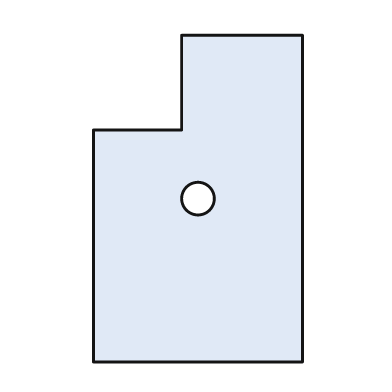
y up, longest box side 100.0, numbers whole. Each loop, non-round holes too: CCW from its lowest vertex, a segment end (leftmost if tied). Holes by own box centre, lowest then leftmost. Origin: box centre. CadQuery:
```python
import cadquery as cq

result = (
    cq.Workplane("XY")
    .moveTo(-32.0, -50.0)
    .lineTo(32.0, -50.0)
    .lineTo(32.0, 50.0)
    .lineTo(-5.0, 50.0)
    .lineTo(-5.0, 21.0)
    .lineTo(-32.0, 21.0)
    .close()
    .moveTo(0.0, 0.0)
    .circle(5.0)
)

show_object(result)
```